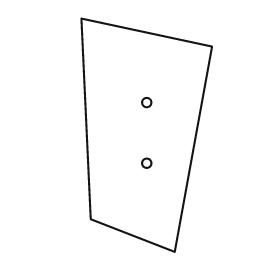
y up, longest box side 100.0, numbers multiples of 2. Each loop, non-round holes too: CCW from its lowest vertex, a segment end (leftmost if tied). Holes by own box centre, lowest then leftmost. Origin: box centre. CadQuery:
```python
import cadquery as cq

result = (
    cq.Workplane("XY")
    .moveTo(12.0, -50.0)
    .lineTo(28.0, 38.0)
    .lineTo(-28.0, 50.0)
    .lineTo(-24.0, -36.0)
    .close()
    .moveTo(0.0, -12.0)
    .circle(2.0)
    .moveTo(0.0, 14.0)
    .circle(2.0)
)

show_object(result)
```